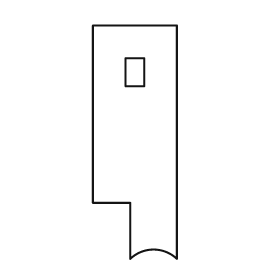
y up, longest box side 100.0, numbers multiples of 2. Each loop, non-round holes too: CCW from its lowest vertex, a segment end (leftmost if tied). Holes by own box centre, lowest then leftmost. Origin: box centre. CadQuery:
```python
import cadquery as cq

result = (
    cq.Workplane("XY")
    .moveTo(-2.0, -50.0)
    .threePointArc((8.0, -46.0), (18.0, -50.0))
    .lineTo(18.0, 50.0)
    .lineTo(-18.0, 50.0)
    .lineTo(-18.0, -26.0)
    .lineTo(-2.0, -26.0)
    .close()
    .moveTo(-4.0, 24.0)
    .lineTo(4.0, 24.0)
    .lineTo(4.0, 36.0)
    .lineTo(-4.0, 36.0)
    .close()
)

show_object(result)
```